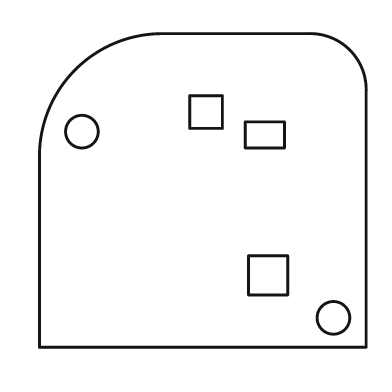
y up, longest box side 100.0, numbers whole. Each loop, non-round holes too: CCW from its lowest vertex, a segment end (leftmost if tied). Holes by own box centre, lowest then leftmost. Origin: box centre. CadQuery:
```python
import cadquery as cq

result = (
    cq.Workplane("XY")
    .moveTo(-50.0, -48.0)
    .lineTo(50.0, -48.0)
    .lineTo(50.0, 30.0)
    .threePointArc((45.0, 43.0), (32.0, 48.0))
    .lineTo(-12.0, 48.0)
    .threePointArc((-39.0, 37.0), (-50.0, 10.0))
    .close()
    .moveTo(40.0, -39.0)
    .circle(5.0)
    .moveTo(14.0, -32.0)
    .lineTo(26.0, -32.0)
    .lineTo(26.0, -20.0)
    .lineTo(14.0, -20.0)
    .close()
    .moveTo(13.0, 13.0)
    .lineTo(25.0, 13.0)
    .lineTo(25.0, 21.0)
    .lineTo(13.0, 21.0)
    .close()
    .moveTo(-37.0, 18.0)
    .circle(5.0)
    .moveTo(-4.0, 19.0)
    .lineTo(6.0, 19.0)
    .lineTo(6.0, 29.0)
    .lineTo(-4.0, 29.0)
    .close()
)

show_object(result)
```